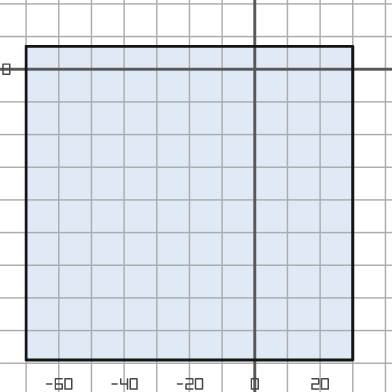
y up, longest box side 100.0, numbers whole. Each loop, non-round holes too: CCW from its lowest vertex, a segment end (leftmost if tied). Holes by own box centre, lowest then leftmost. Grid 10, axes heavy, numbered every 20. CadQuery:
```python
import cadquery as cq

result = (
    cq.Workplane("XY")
    .moveTo(-70.0, -89.0)
    .lineTo(30.0, -89.0)
    .lineTo(30.0, 7.0)
    .lineTo(-70.0, 7.0)
    .close()
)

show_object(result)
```